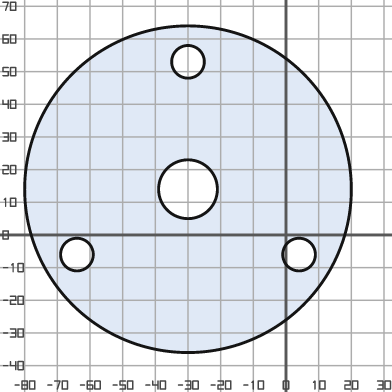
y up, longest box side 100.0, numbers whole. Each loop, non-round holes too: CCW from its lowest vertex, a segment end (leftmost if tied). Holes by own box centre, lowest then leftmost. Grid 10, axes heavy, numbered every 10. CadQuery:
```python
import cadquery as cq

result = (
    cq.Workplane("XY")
    .moveTo(-30.0, 14.0)
    .circle(50.0)
    .moveTo(-64.0, -6.0)
    .circle(5.0)
    .moveTo(4.0, -6.0)
    .circle(5.0)
    .moveTo(-30.0, 14.0)
    .circle(9.0)
    .moveTo(-30.0, 53.0)
    .circle(5.0)
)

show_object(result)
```